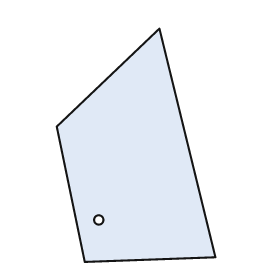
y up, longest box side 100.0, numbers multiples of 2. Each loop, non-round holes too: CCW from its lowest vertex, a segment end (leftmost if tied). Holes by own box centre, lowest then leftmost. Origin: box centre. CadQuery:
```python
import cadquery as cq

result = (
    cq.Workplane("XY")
    .moveTo(-22.0, -50.0)
    .lineTo(34.0, -48.0)
    .lineTo(10.0, 50.0)
    .lineTo(-34.0, 8.0)
    .close()
    .moveTo(-16.0, -32.0)
    .circle(2.0)
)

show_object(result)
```